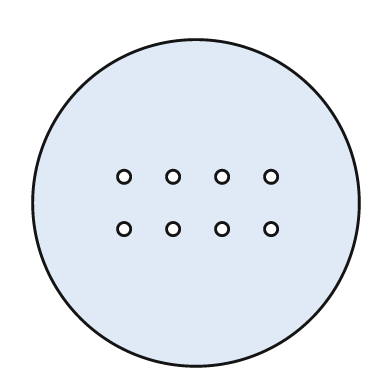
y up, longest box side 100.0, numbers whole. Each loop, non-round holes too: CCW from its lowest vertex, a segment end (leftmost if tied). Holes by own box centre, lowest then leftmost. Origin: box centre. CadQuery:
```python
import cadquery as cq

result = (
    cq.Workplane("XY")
    .moveTo(0.0, 0.0)
    .circle(50.0)
    .moveTo(-22.0, -8.0)
    .circle(2.0)
    .moveTo(-7.0, -8.0)
    .circle(2.0)
    .moveTo(8.0, -8.0)
    .circle(2.0)
    .moveTo(23.0, -8.0)
    .circle(2.0)
    .moveTo(-22.0, 8.0)
    .circle(2.0)
    .moveTo(-7.0, 8.0)
    .circle(2.0)
    .moveTo(8.0, 8.0)
    .circle(2.0)
    .moveTo(23.0, 8.0)
    .circle(2.0)
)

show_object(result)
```